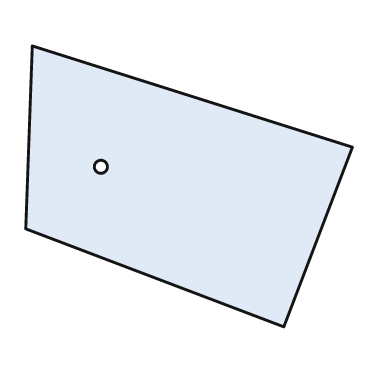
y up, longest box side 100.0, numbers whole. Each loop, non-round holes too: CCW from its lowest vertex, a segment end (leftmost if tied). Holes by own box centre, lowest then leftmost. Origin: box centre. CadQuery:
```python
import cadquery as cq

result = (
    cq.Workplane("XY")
    .moveTo(29.0, -43.0)
    .lineTo(50.0, 12.0)
    .lineTo(-48.0, 43.0)
    .lineTo(-50.0, -13.0)
    .close()
    .moveTo(-27.0, 6.0)
    .circle(2.0)
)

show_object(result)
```